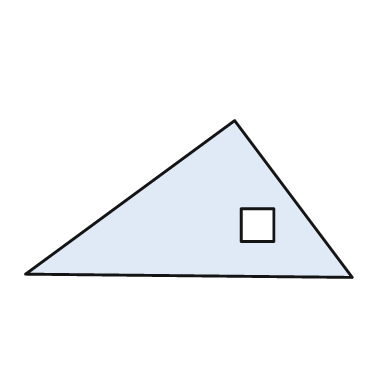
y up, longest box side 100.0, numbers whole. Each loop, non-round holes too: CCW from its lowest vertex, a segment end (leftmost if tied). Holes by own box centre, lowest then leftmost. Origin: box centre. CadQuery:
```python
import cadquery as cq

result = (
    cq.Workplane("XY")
    .moveTo(50.0, -24.0)
    .lineTo(14.0, 24.0)
    .lineTo(-50.0, -23.0)
    .close()
    .moveTo(16.0, -13.0)
    .lineTo(26.0, -13.0)
    .lineTo(26.0, -3.0)
    .lineTo(16.0, -3.0)
    .close()
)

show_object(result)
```